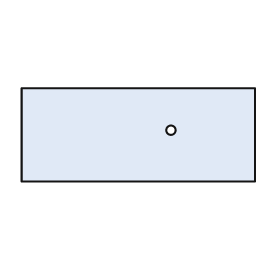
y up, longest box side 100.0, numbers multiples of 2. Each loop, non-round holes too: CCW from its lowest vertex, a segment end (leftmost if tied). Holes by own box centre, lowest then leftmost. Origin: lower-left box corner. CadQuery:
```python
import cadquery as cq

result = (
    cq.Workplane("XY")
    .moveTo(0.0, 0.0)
    .lineTo(100.0, 0.0)
    .lineTo(100.0, 40.0)
    .lineTo(0.0, 40.0)
    .close()
    .moveTo(64.0, 22.0)
    .circle(2.0)
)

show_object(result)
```